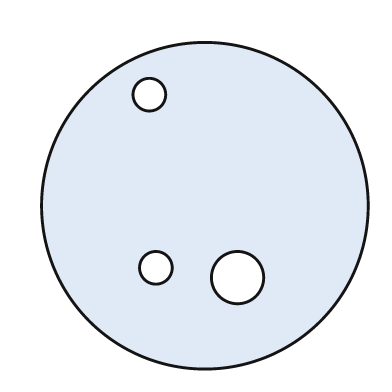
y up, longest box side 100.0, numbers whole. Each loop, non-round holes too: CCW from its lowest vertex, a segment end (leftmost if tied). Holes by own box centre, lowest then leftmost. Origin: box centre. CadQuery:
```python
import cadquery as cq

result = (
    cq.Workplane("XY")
    .moveTo(0.0, 0.0)
    .circle(50.0)
    .moveTo(10.0, -22.0)
    .circle(8.0)
    .moveTo(-15.0, -19.0)
    .circle(5.0)
    .moveTo(-17.0, 34.0)
    .circle(5.0)
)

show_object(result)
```